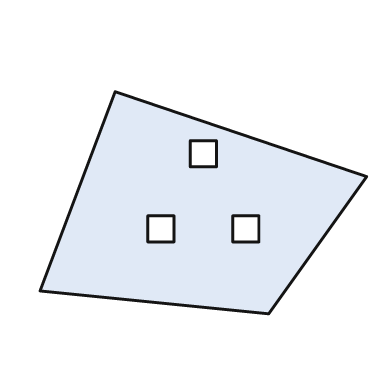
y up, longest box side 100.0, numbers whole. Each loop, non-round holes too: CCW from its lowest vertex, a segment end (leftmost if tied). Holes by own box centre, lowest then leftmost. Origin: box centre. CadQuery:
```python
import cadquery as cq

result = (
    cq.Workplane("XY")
    .moveTo(20.0, -34.0)
    .lineTo(50.0, 8.0)
    .lineTo(-27.0, 34.0)
    .lineTo(-50.0, -27.0)
    .close()
    .moveTo(-17.0, -12.0)
    .lineTo(-9.0, -12.0)
    .lineTo(-9.0, -4.0)
    .lineTo(-17.0, -4.0)
    .close()
    .moveTo(9.0, -12.0)
    .lineTo(17.0, -12.0)
    .lineTo(17.0, -4.0)
    .lineTo(9.0, -4.0)
    .close()
    .moveTo(-4.0, 11.0)
    .lineTo(4.0, 11.0)
    .lineTo(4.0, 19.0)
    .lineTo(-4.0, 19.0)
    .close()
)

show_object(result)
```